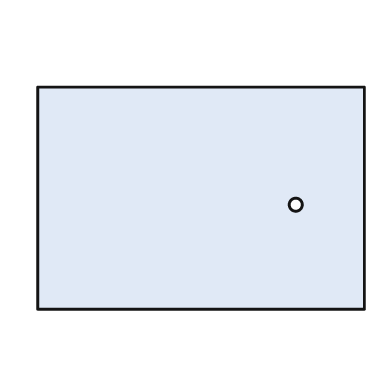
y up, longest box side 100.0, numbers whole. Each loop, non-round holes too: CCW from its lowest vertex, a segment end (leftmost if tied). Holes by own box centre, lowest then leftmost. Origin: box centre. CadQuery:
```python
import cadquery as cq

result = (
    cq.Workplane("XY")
    .moveTo(-50.0, -34.0)
    .lineTo(50.0, -34.0)
    .lineTo(50.0, 34.0)
    .lineTo(-50.0, 34.0)
    .close()
    .moveTo(29.0, -2.0)
    .circle(2.0)
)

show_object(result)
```